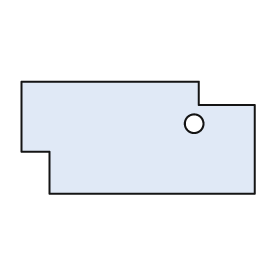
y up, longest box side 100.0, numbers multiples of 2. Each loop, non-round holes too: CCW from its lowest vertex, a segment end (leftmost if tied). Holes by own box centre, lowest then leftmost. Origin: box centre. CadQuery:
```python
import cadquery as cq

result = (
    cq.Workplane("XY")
    .moveTo(-38.0, -24.0)
    .lineTo(50.0, -24.0)
    .lineTo(50.0, 14.0)
    .lineTo(26.0, 14.0)
    .lineTo(26.0, 24.0)
    .lineTo(-50.0, 24.0)
    .lineTo(-50.0, -6.0)
    .lineTo(-38.0, -6.0)
    .close()
    .moveTo(24.0, 6.0)
    .circle(4.0)
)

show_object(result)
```